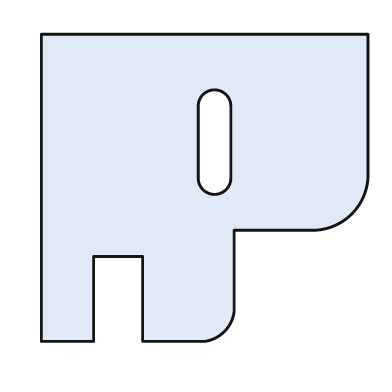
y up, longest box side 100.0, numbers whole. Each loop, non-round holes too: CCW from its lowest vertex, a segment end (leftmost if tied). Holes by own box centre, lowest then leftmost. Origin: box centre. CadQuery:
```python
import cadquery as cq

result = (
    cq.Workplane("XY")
    .moveTo(-50.0, -47.0)
    .lineTo(-34.0, -47.0)
    .lineTo(-34.0, -21.0)
    .lineTo(-19.0, -21.0)
    .lineTo(-19.0, -47.0)
    .lineTo(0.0, -47.0)
    .threePointArc((6.0, -44.0), (9.0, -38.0))
    .lineTo(9.0, -13.0)
    .lineTo(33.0, -13.0)
    .threePointArc((45.0, -8.0), (50.0, 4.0))
    .lineTo(50.0, 47.0)
    .lineTo(-50.0, 47.0)
    .close()
    .moveTo(-2.0, 3.0)
    .threePointArc((3.0, -2.0), (8.0, 3.0))
    .lineTo(8.0, 25.0)
    .threePointArc((3.0, 30.0), (-2.0, 25.0))
    .close()
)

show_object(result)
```